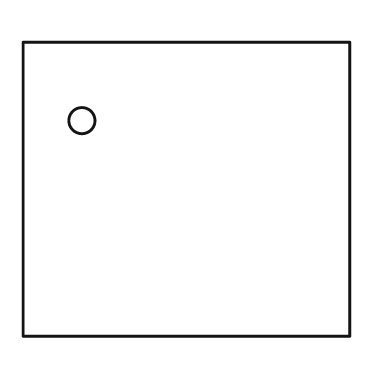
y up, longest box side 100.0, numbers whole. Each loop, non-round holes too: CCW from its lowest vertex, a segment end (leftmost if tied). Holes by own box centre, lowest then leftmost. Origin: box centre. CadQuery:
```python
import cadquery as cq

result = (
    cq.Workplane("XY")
    .moveTo(-50.0, -45.0)
    .lineTo(50.0, -45.0)
    .lineTo(50.0, 45.0)
    .lineTo(-50.0, 45.0)
    .close()
    .moveTo(-32.0, 21.0)
    .circle(4.0)
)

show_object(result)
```